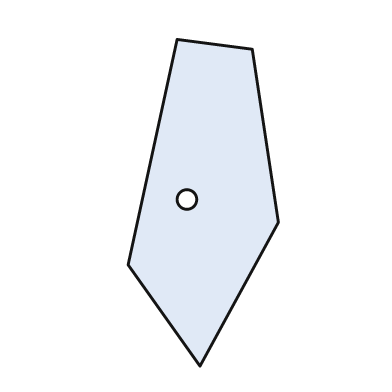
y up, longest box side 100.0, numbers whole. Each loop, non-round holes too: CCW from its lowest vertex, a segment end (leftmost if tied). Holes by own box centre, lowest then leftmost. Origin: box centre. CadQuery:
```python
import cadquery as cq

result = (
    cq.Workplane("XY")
    .moveTo(-1.0, -50.0)
    .lineTo(23.0, -6.0)
    .lineTo(15.0, 47.0)
    .lineTo(-8.0, 50.0)
    .lineTo(-23.0, -19.0)
    .close()
    .moveTo(-5.0, 1.0)
    .circle(3.0)
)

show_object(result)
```